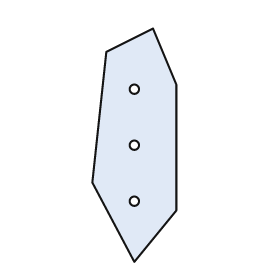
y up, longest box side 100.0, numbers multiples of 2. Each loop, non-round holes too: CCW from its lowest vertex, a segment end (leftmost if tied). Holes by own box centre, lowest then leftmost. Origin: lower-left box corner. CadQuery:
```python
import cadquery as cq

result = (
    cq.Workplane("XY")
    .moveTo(18.0, 0.0)
    .lineTo(36.0, 22.0)
    .lineTo(36.0, 76.0)
    .lineTo(26.0, 100.0)
    .lineTo(6.0, 90.0)
    .lineTo(0.0, 34.0)
    .close()
    .moveTo(18.0, 26.0)
    .circle(2.0)
    .moveTo(18.0, 50.0)
    .circle(2.0)
    .moveTo(18.0, 74.0)
    .circle(2.0)
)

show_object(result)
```